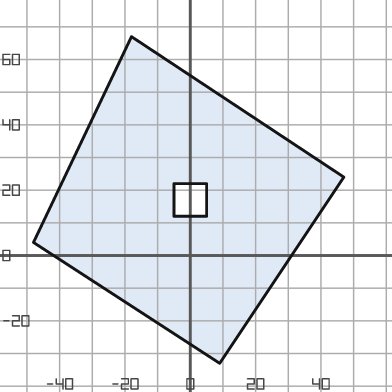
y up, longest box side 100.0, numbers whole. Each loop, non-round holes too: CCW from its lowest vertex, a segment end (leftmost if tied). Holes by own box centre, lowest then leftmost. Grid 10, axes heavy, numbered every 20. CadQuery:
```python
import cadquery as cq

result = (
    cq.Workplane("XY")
    .moveTo(9.0, -33.0)
    .lineTo(47.0, 24.0)
    .lineTo(-18.0, 67.0)
    .lineTo(-48.0, 4.0)
    .close()
    .moveTo(-5.0, 12.0)
    .lineTo(5.0, 12.0)
    .lineTo(5.0, 22.0)
    .lineTo(-5.0, 22.0)
    .close()
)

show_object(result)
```